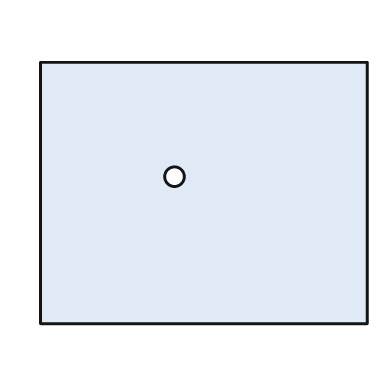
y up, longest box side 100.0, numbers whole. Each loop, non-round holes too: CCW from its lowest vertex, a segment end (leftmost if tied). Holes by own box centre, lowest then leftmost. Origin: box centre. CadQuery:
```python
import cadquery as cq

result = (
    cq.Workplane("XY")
    .moveTo(-50.0, -40.0)
    .lineTo(50.0, -40.0)
    .lineTo(50.0, 40.0)
    .lineTo(-50.0, 40.0)
    .close()
    .moveTo(-9.0, 5.0)
    .circle(3.0)
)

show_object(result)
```